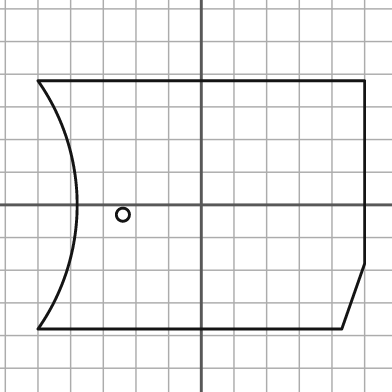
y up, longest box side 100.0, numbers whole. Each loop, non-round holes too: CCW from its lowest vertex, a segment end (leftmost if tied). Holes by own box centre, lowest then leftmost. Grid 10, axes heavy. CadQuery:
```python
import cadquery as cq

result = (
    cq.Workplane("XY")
    .moveTo(-50.0, -38.0)
    .lineTo(43.0, -38.0)
    .lineTo(50.0, -18.0)
    .lineTo(50.0, 38.0)
    .lineTo(-50.0, 38.0)
    .threePointArc((-38.0, 0.0), (-50.0, -38.0))
    .close()
    .moveTo(-24.0, -3.0)
    .circle(2.0)
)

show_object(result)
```